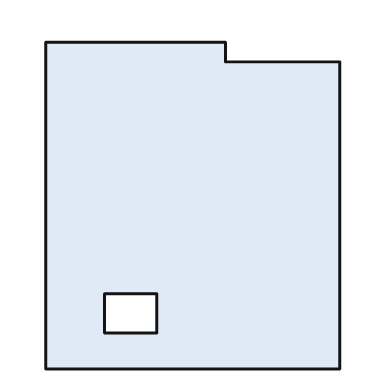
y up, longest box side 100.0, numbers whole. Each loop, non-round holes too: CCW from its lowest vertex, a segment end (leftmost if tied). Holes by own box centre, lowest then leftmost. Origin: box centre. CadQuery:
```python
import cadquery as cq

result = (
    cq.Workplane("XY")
    .moveTo(-45.0, -50.0)
    .lineTo(45.0, -50.0)
    .lineTo(45.0, 44.0)
    .lineTo(10.0, 44.0)
    .lineTo(10.0, 50.0)
    .lineTo(-45.0, 50.0)
    .close()
    .moveTo(-27.0, -39.0)
    .lineTo(-11.0, -39.0)
    .lineTo(-11.0, -27.0)
    .lineTo(-27.0, -27.0)
    .close()
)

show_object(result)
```